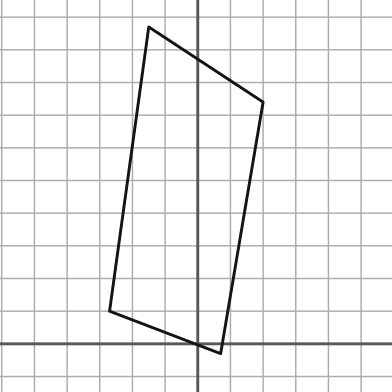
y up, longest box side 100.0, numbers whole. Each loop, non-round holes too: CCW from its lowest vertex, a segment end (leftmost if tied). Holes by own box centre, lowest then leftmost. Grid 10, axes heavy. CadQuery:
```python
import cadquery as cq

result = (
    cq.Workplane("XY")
    .moveTo(7.0, -3.0)
    .lineTo(20.0, 74.0)
    .lineTo(-15.0, 97.0)
    .lineTo(-27.0, 10.0)
    .close()
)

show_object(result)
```